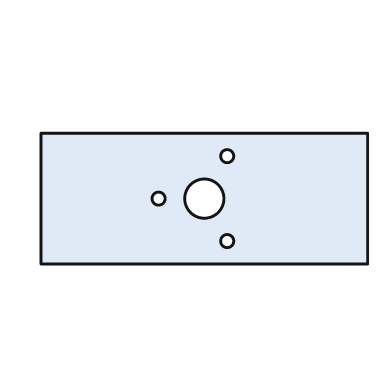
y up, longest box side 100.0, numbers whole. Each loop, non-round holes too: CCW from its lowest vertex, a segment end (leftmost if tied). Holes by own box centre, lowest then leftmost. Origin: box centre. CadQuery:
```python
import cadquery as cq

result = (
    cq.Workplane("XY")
    .moveTo(-50.0, -20.0)
    .lineTo(50.0, -20.0)
    .lineTo(50.0, 20.0)
    .lineTo(-50.0, 20.0)
    .close()
    .moveTo(7.0, -13.0)
    .circle(2.0)
    .moveTo(-14.0, 0.0)
    .circle(2.0)
    .moveTo(0.0, 0.0)
    .circle(6.0)
    .moveTo(7.0, 13.0)
    .circle(2.0)
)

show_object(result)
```